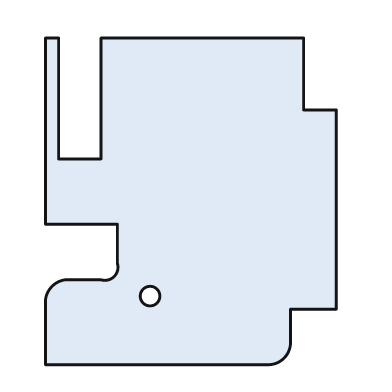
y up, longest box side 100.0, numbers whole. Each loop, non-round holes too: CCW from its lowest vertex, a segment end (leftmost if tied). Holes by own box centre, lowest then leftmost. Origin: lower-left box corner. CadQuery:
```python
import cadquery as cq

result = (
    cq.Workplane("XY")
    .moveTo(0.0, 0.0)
    .lineTo(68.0, 0.0)
    .threePointArc((73.0, 2.0), (75.0, 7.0))
    .lineTo(75.0, 17.0)
    .lineTo(89.0, 17.0)
    .lineTo(89.0, 78.0)
    .lineTo(79.0, 78.0)
    .lineTo(79.0, 100.0)
    .lineTo(17.0, 100.0)
    .lineTo(17.0, 63.0)
    .lineTo(4.0, 63.0)
    .lineTo(4.0, 100.0)
    .lineTo(0.0, 100.0)
    .lineTo(0.0, 43.0)
    .lineTo(22.0, 43.0)
    .lineTo(22.0, 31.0)
    .threePointArc((21.0, 27.0), (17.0, 26.0))
    .lineTo(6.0, 26.0)
    .threePointArc((2.0, 24.0), (0.0, 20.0))
    .close()
    .moveTo(32.0, 21.0)
    .circle(3.0)
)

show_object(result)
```